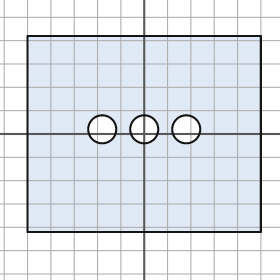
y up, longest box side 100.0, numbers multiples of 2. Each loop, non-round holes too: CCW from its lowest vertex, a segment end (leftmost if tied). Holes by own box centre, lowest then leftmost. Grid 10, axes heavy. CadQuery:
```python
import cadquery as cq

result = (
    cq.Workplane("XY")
    .moveTo(-50.0, -42.0)
    .lineTo(50.0, -42.0)
    .lineTo(50.0, 42.0)
    .lineTo(-50.0, 42.0)
    .close()
    .moveTo(-18.0, 2.0)
    .circle(6.0)
    .moveTo(0.0, 2.0)
    .circle(6.0)
    .moveTo(18.0, 2.0)
    .circle(6.0)
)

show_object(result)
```